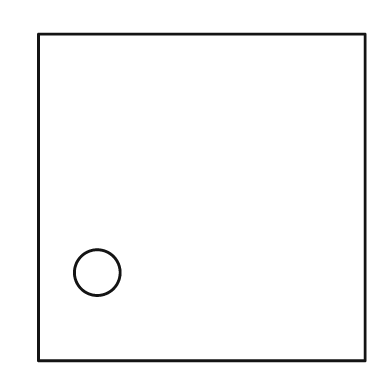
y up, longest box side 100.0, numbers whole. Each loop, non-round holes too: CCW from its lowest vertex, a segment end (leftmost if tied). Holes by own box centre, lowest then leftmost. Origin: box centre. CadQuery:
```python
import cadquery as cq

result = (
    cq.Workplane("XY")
    .moveTo(-50.0, -50.0)
    .lineTo(50.0, -50.0)
    .lineTo(50.0, 50.0)
    .lineTo(-50.0, 50.0)
    .close()
    .moveTo(-32.0, -23.0)
    .circle(7.0)
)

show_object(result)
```